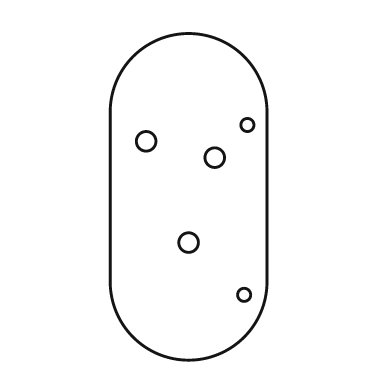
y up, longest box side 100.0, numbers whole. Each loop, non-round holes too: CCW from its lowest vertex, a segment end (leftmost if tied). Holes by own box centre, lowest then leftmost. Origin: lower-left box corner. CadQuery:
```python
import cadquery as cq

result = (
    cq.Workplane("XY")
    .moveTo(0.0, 24.0)
    .threePointArc((24.0, 0.0), (48.0, 24.0))
    .lineTo(48.0, 76.0)
    .threePointArc((24.0, 100.0), (0.0, 76.0))
    .close()
    .moveTo(41.0, 20.0)
    .circle(2.0)
    .moveTo(24.0, 36.0)
    .circle(3.0)
    .moveTo(32.0, 62.0)
    .circle(3.0)
    .moveTo(11.0, 67.0)
    .circle(3.0)
    .moveTo(42.0, 72.0)
    .circle(2.0)
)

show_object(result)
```